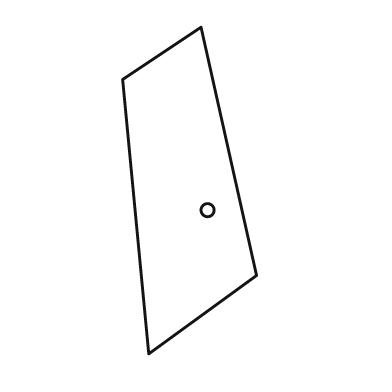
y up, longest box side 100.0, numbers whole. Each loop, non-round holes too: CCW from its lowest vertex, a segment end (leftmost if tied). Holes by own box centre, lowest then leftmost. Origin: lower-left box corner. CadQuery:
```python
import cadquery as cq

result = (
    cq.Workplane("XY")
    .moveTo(8.0, 0.0)
    .lineTo(41.0, 24.0)
    .lineTo(24.0, 100.0)
    .lineTo(0.0, 84.0)
    .close()
    .moveTo(26.0, 44.0)
    .circle(2.0)
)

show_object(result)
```